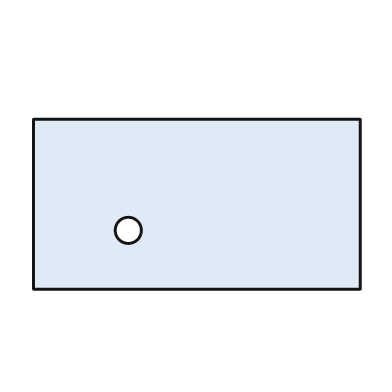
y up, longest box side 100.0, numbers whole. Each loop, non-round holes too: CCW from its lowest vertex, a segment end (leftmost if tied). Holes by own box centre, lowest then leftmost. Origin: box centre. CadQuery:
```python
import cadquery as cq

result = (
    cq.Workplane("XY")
    .moveTo(-50.0, -26.0)
    .lineTo(50.0, -26.0)
    .lineTo(50.0, 26.0)
    .lineTo(-50.0, 26.0)
    .close()
    .moveTo(-21.0, -8.0)
    .circle(4.0)
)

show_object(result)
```